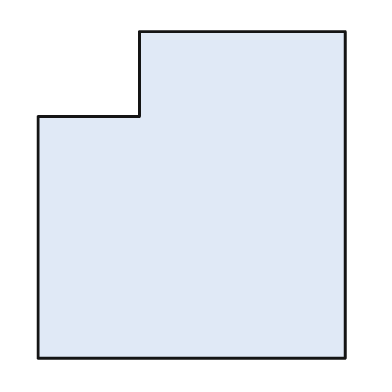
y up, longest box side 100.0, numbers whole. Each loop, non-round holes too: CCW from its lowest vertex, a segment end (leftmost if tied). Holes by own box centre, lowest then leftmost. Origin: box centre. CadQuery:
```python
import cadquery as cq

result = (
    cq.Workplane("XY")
    .moveTo(-47.0, -50.0)
    .lineTo(47.0, -50.0)
    .lineTo(47.0, 50.0)
    .lineTo(-16.0, 50.0)
    .lineTo(-16.0, 24.0)
    .lineTo(-47.0, 24.0)
    .close()
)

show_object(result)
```